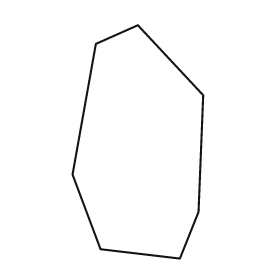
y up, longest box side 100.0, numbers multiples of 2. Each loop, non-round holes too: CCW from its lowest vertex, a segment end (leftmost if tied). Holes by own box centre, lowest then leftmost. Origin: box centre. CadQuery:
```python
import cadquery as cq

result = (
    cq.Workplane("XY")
    .moveTo(18.0, -50.0)
    .lineTo(26.0, -30.0)
    .lineTo(28.0, 20.0)
    .lineTo(0.0, 50.0)
    .lineTo(-18.0, 42.0)
    .lineTo(-28.0, -14.0)
    .lineTo(-16.0, -46.0)
    .close()
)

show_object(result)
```